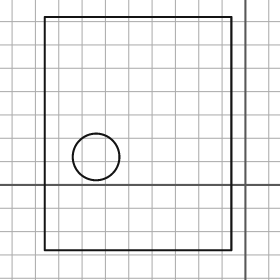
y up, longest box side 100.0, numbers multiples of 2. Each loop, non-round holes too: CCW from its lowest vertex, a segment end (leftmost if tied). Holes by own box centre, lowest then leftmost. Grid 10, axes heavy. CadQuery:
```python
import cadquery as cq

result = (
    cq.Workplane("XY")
    .moveTo(-86.0, -28.0)
    .lineTo(-6.0, -28.0)
    .lineTo(-6.0, 72.0)
    .lineTo(-86.0, 72.0)
    .close()
    .moveTo(-64.0, 12.0)
    .circle(10.0)
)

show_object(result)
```